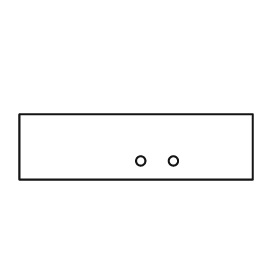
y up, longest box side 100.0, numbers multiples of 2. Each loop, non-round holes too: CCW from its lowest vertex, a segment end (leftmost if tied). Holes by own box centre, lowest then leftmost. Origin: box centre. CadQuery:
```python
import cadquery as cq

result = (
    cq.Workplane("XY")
    .moveTo(-50.0, -14.0)
    .lineTo(50.0, -14.0)
    .lineTo(50.0, 14.0)
    .lineTo(-50.0, 14.0)
    .close()
    .moveTo(2.0, -6.0)
    .circle(2.0)
    .moveTo(16.0, -6.0)
    .circle(2.0)
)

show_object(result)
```